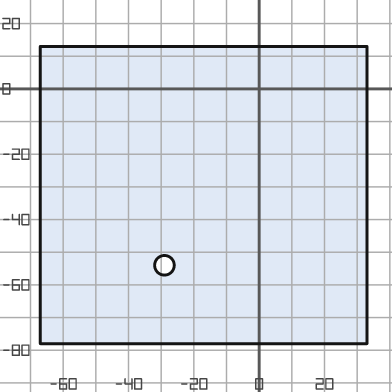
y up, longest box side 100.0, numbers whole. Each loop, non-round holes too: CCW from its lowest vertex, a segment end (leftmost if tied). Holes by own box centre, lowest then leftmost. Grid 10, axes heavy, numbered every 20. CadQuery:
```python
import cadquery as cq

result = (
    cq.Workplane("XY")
    .moveTo(-67.0, -78.0)
    .lineTo(33.0, -78.0)
    .lineTo(33.0, 13.0)
    .lineTo(-67.0, 13.0)
    .close()
    .moveTo(-29.0, -54.0)
    .circle(3.0)
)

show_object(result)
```